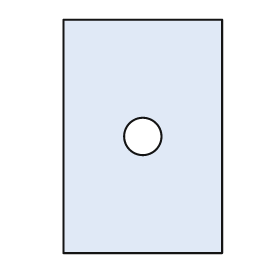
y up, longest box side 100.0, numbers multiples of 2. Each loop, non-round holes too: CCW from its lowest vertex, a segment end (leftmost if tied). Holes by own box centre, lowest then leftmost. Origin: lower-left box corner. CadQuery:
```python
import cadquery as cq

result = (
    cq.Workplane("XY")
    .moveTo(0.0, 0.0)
    .lineTo(68.0, 0.0)
    .lineTo(68.0, 100.0)
    .lineTo(0.0, 100.0)
    .close()
    .moveTo(34.0, 50.0)
    .circle(8.0)
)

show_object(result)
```